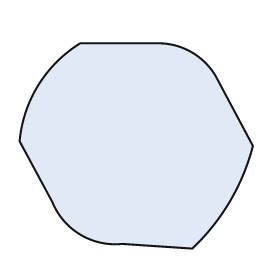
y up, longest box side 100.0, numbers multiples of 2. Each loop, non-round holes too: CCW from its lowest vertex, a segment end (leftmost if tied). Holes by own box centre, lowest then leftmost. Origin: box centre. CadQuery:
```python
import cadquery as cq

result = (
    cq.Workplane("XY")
    .moveTo(24.0, -44.0)
    .threePointArc((40.0, -24.0), (50.0, 0.0))
    .lineTo(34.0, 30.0)
    .threePointArc((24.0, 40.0), (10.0, 44.0))
    .lineTo(-24.0, 44.0)
    .threePointArc((-42.0, 26.0), (-50.0, 2.0))
    .lineTo(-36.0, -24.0)
    .threePointArc((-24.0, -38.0), (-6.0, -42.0))
    .close()
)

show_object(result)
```